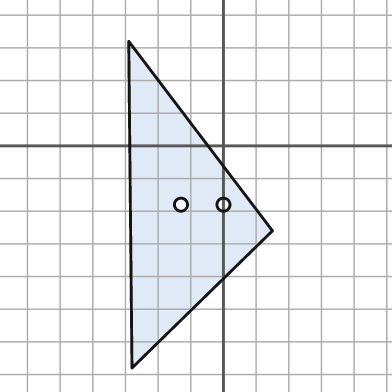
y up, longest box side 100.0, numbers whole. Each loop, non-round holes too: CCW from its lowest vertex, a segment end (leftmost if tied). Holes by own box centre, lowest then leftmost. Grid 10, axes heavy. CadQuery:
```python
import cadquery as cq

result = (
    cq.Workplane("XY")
    .moveTo(-28.0, -68.0)
    .lineTo(15.0, -26.0)
    .lineTo(-29.0, 32.0)
    .close()
    .moveTo(-13.0, -18.0)
    .circle(2.0)
    .moveTo(0.0, -18.0)
    .circle(2.0)
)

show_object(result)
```